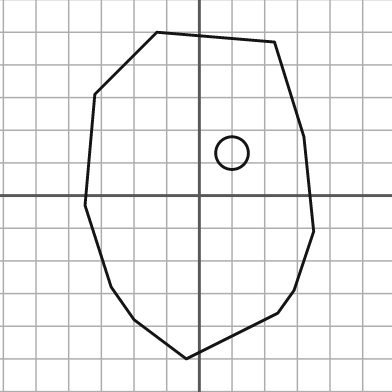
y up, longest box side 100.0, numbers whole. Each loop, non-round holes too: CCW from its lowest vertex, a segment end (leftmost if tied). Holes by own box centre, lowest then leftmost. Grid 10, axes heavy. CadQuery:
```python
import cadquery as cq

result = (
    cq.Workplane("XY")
    .moveTo(-4.0, -50.0)
    .lineTo(24.0, -36.0)
    .lineTo(29.0, -29.0)
    .lineTo(35.0, -11.0)
    .lineTo(32.0, 18.0)
    .lineTo(23.0, 47.0)
    .lineTo(-13.0, 50.0)
    .lineTo(-32.0, 31.0)
    .lineTo(-35.0, -3.0)
    .lineTo(-27.0, -28.0)
    .lineTo(-20.0, -38.0)
    .close()
    .moveTo(10.0, 13.0)
    .circle(5.0)
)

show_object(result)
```